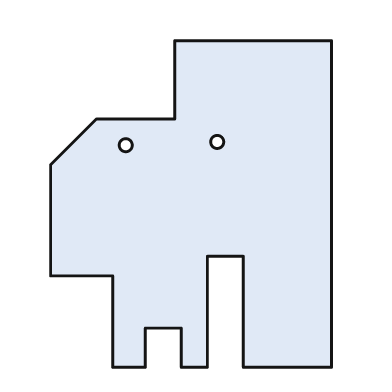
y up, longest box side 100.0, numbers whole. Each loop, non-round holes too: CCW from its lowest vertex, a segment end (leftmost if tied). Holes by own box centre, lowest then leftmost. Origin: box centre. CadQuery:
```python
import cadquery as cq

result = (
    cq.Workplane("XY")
    .moveTo(-24.0, -50.0)
    .lineTo(-14.0, -50.0)
    .lineTo(-14.0, -38.0)
    .lineTo(-3.0, -38.0)
    .lineTo(-3.0, -50.0)
    .lineTo(5.0, -50.0)
    .lineTo(5.0, -16.0)
    .lineTo(16.0, -16.0)
    .lineTo(16.0, -50.0)
    .lineTo(43.0, -50.0)
    .lineTo(43.0, 50.0)
    .lineTo(-5.0, 50.0)
    .lineTo(-5.0, 26.0)
    .lineTo(-29.0, 26.0)
    .lineTo(-43.0, 12.0)
    .lineTo(-43.0, -22.0)
    .lineTo(-24.0, -22.0)
    .close()
    .moveTo(-20.0, 18.0)
    .circle(2.0)
    .moveTo(8.0, 19.0)
    .circle(2.0)
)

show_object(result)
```